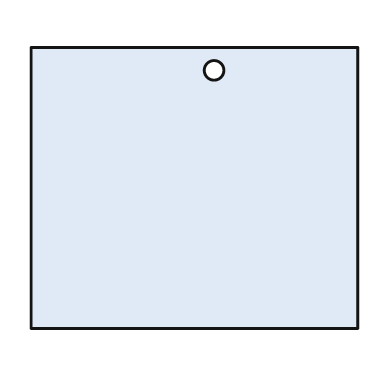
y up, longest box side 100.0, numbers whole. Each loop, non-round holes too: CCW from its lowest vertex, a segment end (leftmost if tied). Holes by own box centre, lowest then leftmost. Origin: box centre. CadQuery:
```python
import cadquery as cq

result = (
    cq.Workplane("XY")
    .moveTo(-50.0, -43.0)
    .lineTo(50.0, -43.0)
    .lineTo(50.0, 43.0)
    .lineTo(-50.0, 43.0)
    .close()
    .moveTo(6.0, 36.0)
    .circle(3.0)
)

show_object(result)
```